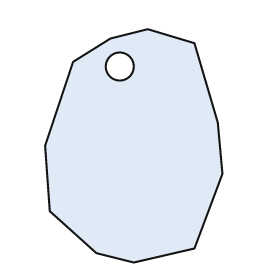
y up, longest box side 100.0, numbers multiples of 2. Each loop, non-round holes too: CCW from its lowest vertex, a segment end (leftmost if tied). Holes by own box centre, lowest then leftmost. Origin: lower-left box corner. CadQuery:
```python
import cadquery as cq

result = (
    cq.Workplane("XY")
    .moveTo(38.0, 0.0)
    .lineTo(64.0, 6.0)
    .lineTo(76.0, 38.0)
    .lineTo(74.0, 60.0)
    .lineTo(64.0, 94.0)
    .lineTo(44.0, 100.0)
    .lineTo(28.0, 96.0)
    .lineTo(12.0, 86.0)
    .lineTo(0.0, 50.0)
    .lineTo(2.0, 22.0)
    .lineTo(22.0, 4.0)
    .close()
    .moveTo(32.0, 84.0)
    .circle(6.0)
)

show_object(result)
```